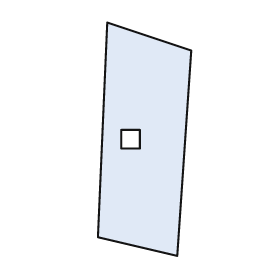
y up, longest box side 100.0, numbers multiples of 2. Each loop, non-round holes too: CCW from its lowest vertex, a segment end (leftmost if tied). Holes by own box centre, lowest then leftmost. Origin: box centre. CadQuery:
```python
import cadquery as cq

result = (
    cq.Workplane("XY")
    .moveTo(14.0, -50.0)
    .lineTo(20.0, 38.0)
    .lineTo(-16.0, 50.0)
    .lineTo(-20.0, -42.0)
    .close()
    .moveTo(-10.0, -4.0)
    .lineTo(-2.0, -4.0)
    .lineTo(-2.0, 4.0)
    .lineTo(-10.0, 4.0)
    .close()
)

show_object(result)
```